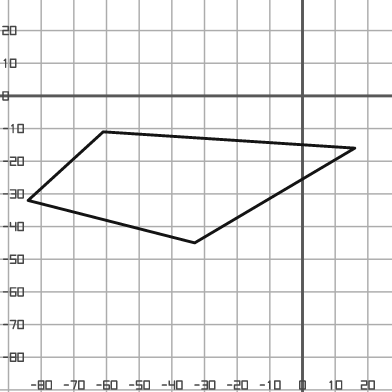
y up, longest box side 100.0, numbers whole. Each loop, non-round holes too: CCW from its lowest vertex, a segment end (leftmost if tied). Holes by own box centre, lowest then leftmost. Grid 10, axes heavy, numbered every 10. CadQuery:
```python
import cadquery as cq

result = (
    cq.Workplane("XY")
    .moveTo(-33.0, -45.0)
    .lineTo(16.0, -16.0)
    .lineTo(-61.0, -11.0)
    .lineTo(-84.0, -32.0)
    .close()
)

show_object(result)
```